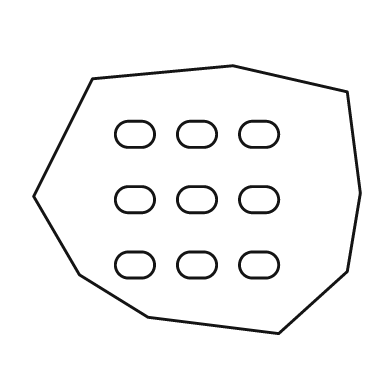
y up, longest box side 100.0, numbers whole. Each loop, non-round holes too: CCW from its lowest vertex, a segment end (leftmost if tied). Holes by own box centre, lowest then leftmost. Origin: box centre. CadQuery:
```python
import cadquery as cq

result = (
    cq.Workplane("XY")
    .moveTo(25.0, -41.0)
    .lineTo(46.0, -22.0)
    .lineTo(50.0, 2.0)
    .lineTo(46.0, 33.0)
    .lineTo(11.0, 41.0)
    .lineTo(-32.0, 37.0)
    .lineTo(-50.0, 1.0)
    .lineTo(-36.0, -23.0)
    .lineTo(-15.0, -36.0)
    .close()
    .moveTo(-21.0, -24.0)
    .lineTo(-17.0, -24.0)
    .threePointArc((-13.0, -20.0), (-17.0, -16.0))
    .lineTo(-21.0, -16.0)
    .threePointArc((-25.0, -20.0), (-21.0, -24.0))
    .close()
    .moveTo(-2.0, -24.0)
    .lineTo(2.0, -24.0)
    .threePointArc((6.0, -20.0), (2.0, -16.0))
    .lineTo(-2.0, -16.0)
    .threePointArc((-6.0, -20.0), (-2.0, -24.0))
    .close()
    .moveTo(17.0, -24.0)
    .lineTo(21.0, -24.0)
    .threePointArc((25.0, -20.0), (21.0, -16.0))
    .lineTo(17.0, -16.0)
    .threePointArc((13.0, -20.0), (17.0, -24.0))
    .close()
    .moveTo(-21.0, -4.0)
    .lineTo(-17.0, -4.0)
    .threePointArc((-13.0, 0.0), (-17.0, 4.0))
    .lineTo(-21.0, 4.0)
    .threePointArc((-25.0, 0.0), (-21.0, -4.0))
    .close()
    .moveTo(-2.0, -4.0)
    .lineTo(2.0, -4.0)
    .threePointArc((6.0, 0.0), (2.0, 4.0))
    .lineTo(-2.0, 4.0)
    .threePointArc((-6.0, 0.0), (-2.0, -4.0))
    .close()
    .moveTo(17.0, -4.0)
    .lineTo(21.0, -4.0)
    .threePointArc((25.0, 0.0), (21.0, 4.0))
    .lineTo(17.0, 4.0)
    .threePointArc((13.0, 0.0), (17.0, -4.0))
    .close()
    .moveTo(-21.0, 16.0)
    .lineTo(-17.0, 16.0)
    .threePointArc((-13.0, 20.0), (-17.0, 24.0))
    .lineTo(-21.0, 24.0)
    .threePointArc((-25.0, 20.0), (-21.0, 16.0))
    .close()
    .moveTo(-2.0, 16.0)
    .lineTo(2.0, 16.0)
    .threePointArc((6.0, 20.0), (2.0, 24.0))
    .lineTo(-2.0, 24.0)
    .threePointArc((-6.0, 20.0), (-2.0, 16.0))
    .close()
    .moveTo(17.0, 16.0)
    .lineTo(21.0, 16.0)
    .threePointArc((25.0, 20.0), (21.0, 24.0))
    .lineTo(17.0, 24.0)
    .threePointArc((13.0, 20.0), (17.0, 16.0))
    .close()
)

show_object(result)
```